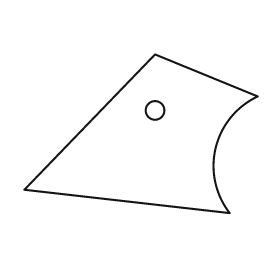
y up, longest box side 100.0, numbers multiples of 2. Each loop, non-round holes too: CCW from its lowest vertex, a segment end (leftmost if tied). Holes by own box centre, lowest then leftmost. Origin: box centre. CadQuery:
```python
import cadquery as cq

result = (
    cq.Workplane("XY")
    .moveTo(38.0, -34.0)
    .threePointArc((32.0, -6.0), (50.0, 16.0))
    .lineTo(6.0, 34.0)
    .lineTo(-50.0, -24.0)
    .close()
    .moveTo(6.0, 10.0)
    .circle(4.0)
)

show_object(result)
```